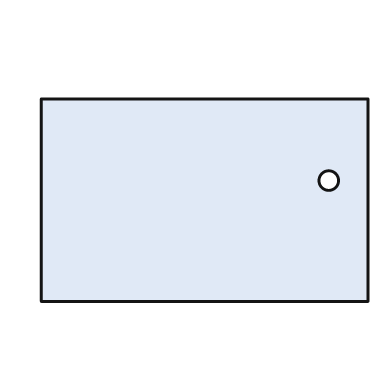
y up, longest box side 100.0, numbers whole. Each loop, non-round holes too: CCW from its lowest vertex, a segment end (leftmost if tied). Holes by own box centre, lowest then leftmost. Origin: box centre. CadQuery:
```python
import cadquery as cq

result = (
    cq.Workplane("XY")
    .moveTo(-50.0, -31.0)
    .lineTo(50.0, -31.0)
    .lineTo(50.0, 31.0)
    .lineTo(-50.0, 31.0)
    .close()
    .moveTo(38.0, 6.0)
    .circle(3.0)
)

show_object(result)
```